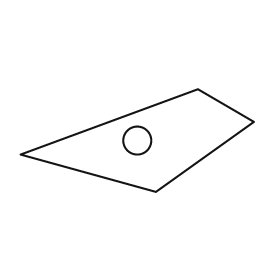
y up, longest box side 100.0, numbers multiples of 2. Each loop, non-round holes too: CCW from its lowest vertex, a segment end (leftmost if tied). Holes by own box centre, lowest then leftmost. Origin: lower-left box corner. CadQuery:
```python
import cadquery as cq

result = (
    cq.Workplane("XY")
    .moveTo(58.0, 0.0)
    .lineTo(100.0, 30.0)
    .lineTo(76.0, 44.0)
    .lineTo(0.0, 16.0)
    .close()
    .moveTo(50.0, 22.0)
    .circle(6.0)
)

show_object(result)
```